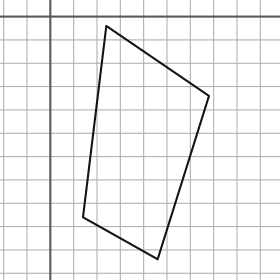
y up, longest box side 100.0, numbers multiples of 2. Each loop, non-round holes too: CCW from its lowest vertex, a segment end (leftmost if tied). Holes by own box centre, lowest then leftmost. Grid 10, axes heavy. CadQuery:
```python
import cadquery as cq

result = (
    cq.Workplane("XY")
    .moveTo(46.0, -104.0)
    .lineTo(68.0, -34.0)
    .lineTo(24.0, -4.0)
    .lineTo(14.0, -86.0)
    .close()
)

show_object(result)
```